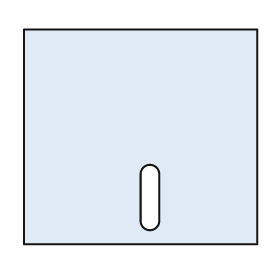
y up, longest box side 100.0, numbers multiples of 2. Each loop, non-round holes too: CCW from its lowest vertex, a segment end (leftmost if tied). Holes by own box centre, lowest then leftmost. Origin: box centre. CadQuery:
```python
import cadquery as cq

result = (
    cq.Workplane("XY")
    .moveTo(-50.0, -46.0)
    .lineTo(50.0, -46.0)
    .lineTo(50.0, 46.0)
    .lineTo(-50.0, 46.0)
    .close()
    .moveTo(0.0, -36.0)
    .threePointArc((4.0, -40.0), (8.0, -36.0))
    .lineTo(8.0, -16.0)
    .threePointArc((4.0, -12.0), (0.0, -16.0))
    .close()
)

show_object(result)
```